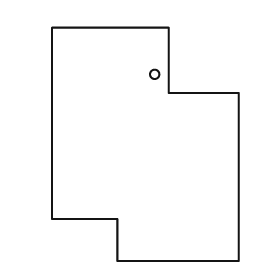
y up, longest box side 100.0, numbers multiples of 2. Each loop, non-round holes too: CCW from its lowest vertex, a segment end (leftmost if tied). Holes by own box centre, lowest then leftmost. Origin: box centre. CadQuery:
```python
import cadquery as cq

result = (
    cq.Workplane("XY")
    .moveTo(-12.0, -50.0)
    .lineTo(40.0, -50.0)
    .lineTo(40.0, 22.0)
    .lineTo(10.0, 22.0)
    .lineTo(10.0, 50.0)
    .lineTo(-40.0, 50.0)
    .lineTo(-40.0, -32.0)
    .lineTo(-12.0, -32.0)
    .close()
    .moveTo(4.0, 30.0)
    .circle(2.0)
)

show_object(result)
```